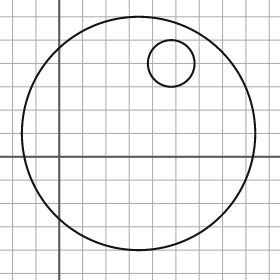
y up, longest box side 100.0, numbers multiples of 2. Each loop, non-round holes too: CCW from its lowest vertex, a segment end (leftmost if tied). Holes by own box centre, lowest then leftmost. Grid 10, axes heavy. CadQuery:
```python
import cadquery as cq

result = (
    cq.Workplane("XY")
    .moveTo(34.0, 10.0)
    .circle(50.0)
    .moveTo(48.0, 40.0)
    .circle(10.0)
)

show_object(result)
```